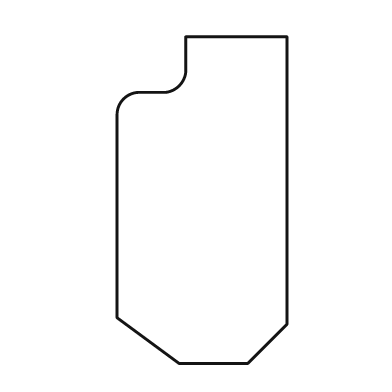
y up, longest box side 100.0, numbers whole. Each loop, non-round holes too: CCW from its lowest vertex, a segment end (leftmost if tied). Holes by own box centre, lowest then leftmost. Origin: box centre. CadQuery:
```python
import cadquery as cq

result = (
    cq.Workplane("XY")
    .moveTo(-7.0, -50.0)
    .lineTo(14.0, -50.0)
    .lineTo(26.0, -38.0)
    .lineTo(26.0, 50.0)
    .lineTo(-5.0, 50.0)
    .lineTo(-5.0, 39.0)
    .threePointArc((-7.0, 35.0), (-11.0, 33.0))
    .lineTo(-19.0, 33.0)
    .threePointArc((-24.0, 31.0), (-26.0, 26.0))
    .lineTo(-26.0, -36.0)
    .close()
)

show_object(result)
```